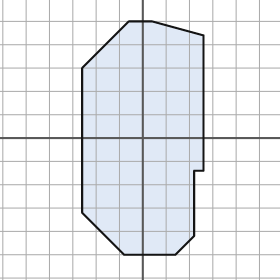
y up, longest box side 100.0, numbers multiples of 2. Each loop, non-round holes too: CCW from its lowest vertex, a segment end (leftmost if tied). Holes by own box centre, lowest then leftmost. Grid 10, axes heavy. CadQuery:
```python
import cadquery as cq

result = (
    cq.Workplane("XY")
    .moveTo(-8.0, -50.0)
    .lineTo(14.0, -50.0)
    .lineTo(22.0, -42.0)
    .lineTo(22.0, -14.0)
    .lineTo(26.0, -14.0)
    .lineTo(26.0, 44.0)
    .lineTo(4.0, 50.0)
    .lineTo(-6.0, 50.0)
    .lineTo(-26.0, 30.0)
    .lineTo(-26.0, -32.0)
    .close()
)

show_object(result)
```